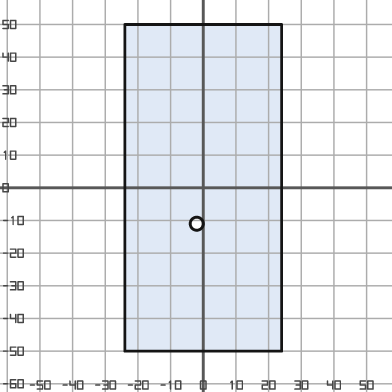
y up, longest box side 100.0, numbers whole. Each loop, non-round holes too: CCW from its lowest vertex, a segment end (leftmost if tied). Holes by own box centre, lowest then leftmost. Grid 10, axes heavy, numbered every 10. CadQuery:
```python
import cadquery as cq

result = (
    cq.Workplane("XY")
    .moveTo(-24.0, -50.0)
    .lineTo(24.0, -50.0)
    .lineTo(24.0, 50.0)
    .lineTo(-24.0, 50.0)
    .close()
    .moveTo(-2.0, -11.0)
    .circle(2.0)
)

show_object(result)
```